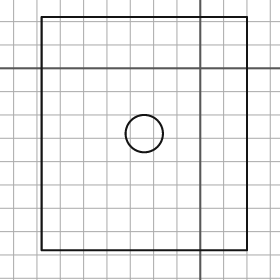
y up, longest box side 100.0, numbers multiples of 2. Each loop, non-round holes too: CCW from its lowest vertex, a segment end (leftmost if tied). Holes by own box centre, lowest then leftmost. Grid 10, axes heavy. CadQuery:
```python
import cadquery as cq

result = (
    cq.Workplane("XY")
    .moveTo(-68.0, -78.0)
    .lineTo(20.0, -78.0)
    .lineTo(20.0, 22.0)
    .lineTo(-68.0, 22.0)
    .close()
    .moveTo(-24.0, -28.0)
    .circle(8.0)
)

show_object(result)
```